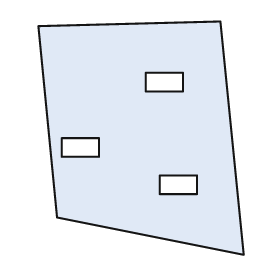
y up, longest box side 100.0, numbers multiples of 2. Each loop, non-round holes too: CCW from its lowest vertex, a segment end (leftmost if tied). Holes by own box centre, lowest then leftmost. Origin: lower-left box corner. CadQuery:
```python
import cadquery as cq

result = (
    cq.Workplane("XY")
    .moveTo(88.0, 0.0)
    .lineTo(78.0, 100.0)
    .lineTo(0.0, 98.0)
    .lineTo(8.0, 16.0)
    .close()
    .moveTo(52.0, 26.0)
    .lineTo(68.0, 26.0)
    .lineTo(68.0, 34.0)
    .lineTo(52.0, 34.0)
    .close()
    .moveTo(10.0, 42.0)
    .lineTo(26.0, 42.0)
    .lineTo(26.0, 50.0)
    .lineTo(10.0, 50.0)
    .close()
    .moveTo(46.0, 70.0)
    .lineTo(62.0, 70.0)
    .lineTo(62.0, 78.0)
    .lineTo(46.0, 78.0)
    .close()
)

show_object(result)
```